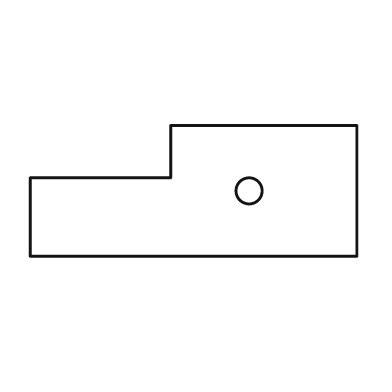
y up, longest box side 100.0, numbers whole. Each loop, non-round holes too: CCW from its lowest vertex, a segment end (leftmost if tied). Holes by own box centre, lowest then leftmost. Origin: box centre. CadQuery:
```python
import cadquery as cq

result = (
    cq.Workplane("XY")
    .moveTo(-50.0, -20.0)
    .lineTo(50.0, -20.0)
    .lineTo(50.0, 20.0)
    .lineTo(-7.0, 20.0)
    .lineTo(-7.0, 4.0)
    .lineTo(-50.0, 4.0)
    .close()
    .moveTo(17.0, 0.0)
    .circle(4.0)
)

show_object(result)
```